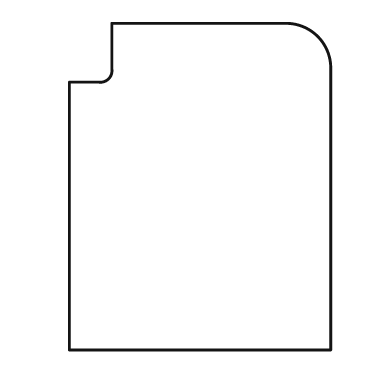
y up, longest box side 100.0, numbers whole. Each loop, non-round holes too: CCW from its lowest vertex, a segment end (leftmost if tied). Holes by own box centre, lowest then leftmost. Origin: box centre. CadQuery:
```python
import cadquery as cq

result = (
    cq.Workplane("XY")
    .moveTo(-40.0, -50.0)
    .lineTo(40.0, -50.0)
    .lineTo(40.0, 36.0)
    .threePointArc((36.0, 46.0), (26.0, 50.0))
    .lineTo(-27.0, 50.0)
    .lineTo(-27.0, 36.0)
    .threePointArc((-28.0, 33.0), (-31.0, 32.0))
    .lineTo(-40.0, 32.0)
    .close()
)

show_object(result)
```